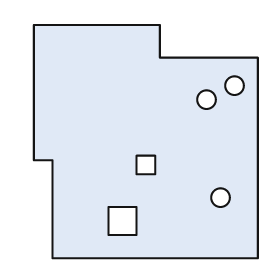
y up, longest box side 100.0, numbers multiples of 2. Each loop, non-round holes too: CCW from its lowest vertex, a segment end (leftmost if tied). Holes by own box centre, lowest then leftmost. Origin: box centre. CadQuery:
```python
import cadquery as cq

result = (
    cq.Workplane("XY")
    .moveTo(-40.0, -50.0)
    .lineTo(48.0, -50.0)
    .lineTo(48.0, 36.0)
    .lineTo(6.0, 36.0)
    .lineTo(6.0, 50.0)
    .lineTo(-48.0, 50.0)
    .lineTo(-48.0, -8.0)
    .lineTo(-40.0, -8.0)
    .close()
    .moveTo(-16.0, -40.0)
    .lineTo(-4.0, -40.0)
    .lineTo(-4.0, -28.0)
    .lineTo(-16.0, -28.0)
    .close()
    .moveTo(32.0, -24.0)
    .circle(4.0)
    .moveTo(-4.0, -14.0)
    .lineTo(4.0, -14.0)
    .lineTo(4.0, -6.0)
    .lineTo(-4.0, -6.0)
    .close()
    .moveTo(26.0, 18.0)
    .circle(4.0)
    .moveTo(38.0, 24.0)
    .circle(4.0)
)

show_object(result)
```